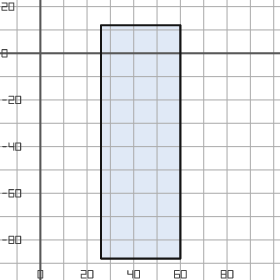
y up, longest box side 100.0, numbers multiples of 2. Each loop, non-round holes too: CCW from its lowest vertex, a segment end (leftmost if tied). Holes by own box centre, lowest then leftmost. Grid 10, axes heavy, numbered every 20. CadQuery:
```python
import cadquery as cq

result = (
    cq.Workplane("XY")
    .moveTo(26.0, -88.0)
    .lineTo(60.0, -88.0)
    .lineTo(60.0, 12.0)
    .lineTo(26.0, 12.0)
    .close()
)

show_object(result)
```